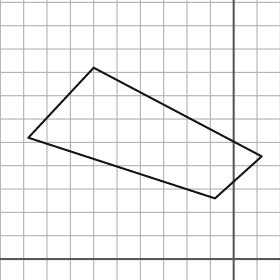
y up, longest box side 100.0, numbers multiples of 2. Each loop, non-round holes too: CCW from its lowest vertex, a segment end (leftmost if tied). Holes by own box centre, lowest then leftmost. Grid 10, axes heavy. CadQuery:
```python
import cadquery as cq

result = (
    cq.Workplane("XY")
    .moveTo(-8.0, 26.0)
    .lineTo(12.0, 44.0)
    .lineTo(-60.0, 82.0)
    .lineTo(-88.0, 52.0)
    .close()
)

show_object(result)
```